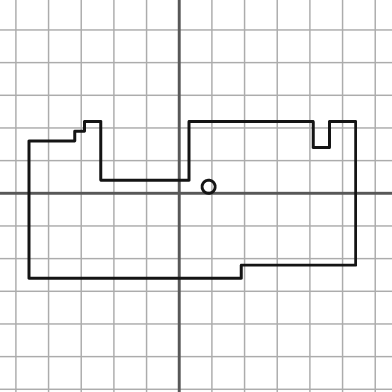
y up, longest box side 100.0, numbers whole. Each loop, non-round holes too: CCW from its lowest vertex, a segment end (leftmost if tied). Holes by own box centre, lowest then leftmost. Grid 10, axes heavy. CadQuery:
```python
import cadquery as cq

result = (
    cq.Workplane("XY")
    .moveTo(-46.0, -26.0)
    .lineTo(19.0, -26.0)
    .lineTo(19.0, -22.0)
    .lineTo(54.0, -22.0)
    .lineTo(54.0, 22.0)
    .lineTo(46.0, 22.0)
    .lineTo(46.0, 14.0)
    .lineTo(41.0, 14.0)
    .lineTo(41.0, 22.0)
    .lineTo(3.0, 22.0)
    .lineTo(3.0, 4.0)
    .lineTo(-24.0, 4.0)
    .lineTo(-24.0, 22.0)
    .lineTo(-29.0, 22.0)
    .lineTo(-29.0, 19.0)
    .lineTo(-32.0, 19.0)
    .lineTo(-32.0, 16.0)
    .lineTo(-46.0, 16.0)
    .close()
    .moveTo(9.0, 2.0)
    .circle(2.0)
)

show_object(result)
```